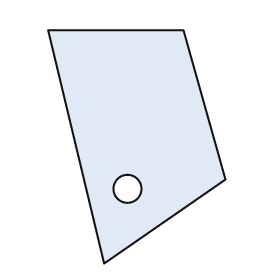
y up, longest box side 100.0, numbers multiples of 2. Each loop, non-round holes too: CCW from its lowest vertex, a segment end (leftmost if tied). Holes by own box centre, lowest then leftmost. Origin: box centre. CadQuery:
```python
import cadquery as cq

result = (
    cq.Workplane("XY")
    .moveTo(-14.0, -50.0)
    .lineTo(38.0, -14.0)
    .lineTo(20.0, 50.0)
    .lineTo(-38.0, 50.0)
    .close()
    .moveTo(-4.0, -18.0)
    .circle(6.0)
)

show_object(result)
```